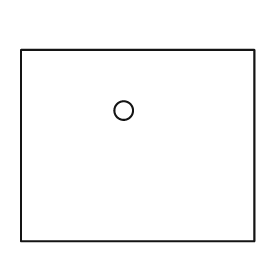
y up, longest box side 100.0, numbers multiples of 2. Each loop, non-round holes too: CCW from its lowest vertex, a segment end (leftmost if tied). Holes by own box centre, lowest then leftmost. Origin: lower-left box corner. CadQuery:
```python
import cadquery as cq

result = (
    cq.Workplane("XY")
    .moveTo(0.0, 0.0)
    .lineTo(100.0, 0.0)
    .lineTo(100.0, 82.0)
    .lineTo(0.0, 82.0)
    .close()
    .moveTo(44.0, 56.0)
    .circle(4.0)
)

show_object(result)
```